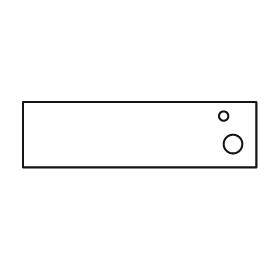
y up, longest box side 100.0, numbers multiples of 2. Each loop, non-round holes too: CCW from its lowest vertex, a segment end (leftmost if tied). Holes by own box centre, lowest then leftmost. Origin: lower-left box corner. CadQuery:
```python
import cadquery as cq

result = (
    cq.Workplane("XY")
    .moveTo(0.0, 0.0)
    .lineTo(100.0, 0.0)
    .lineTo(100.0, 28.0)
    .lineTo(0.0, 28.0)
    .close()
    .moveTo(90.0, 10.0)
    .circle(4.0)
    .moveTo(86.0, 22.0)
    .circle(2.0)
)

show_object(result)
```